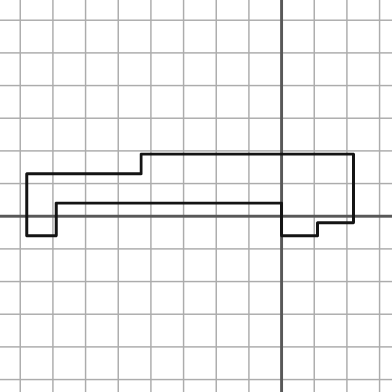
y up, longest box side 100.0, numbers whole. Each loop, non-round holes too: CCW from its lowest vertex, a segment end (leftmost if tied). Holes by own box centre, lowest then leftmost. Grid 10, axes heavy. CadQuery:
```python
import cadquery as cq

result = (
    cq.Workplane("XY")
    .moveTo(-78.0, -6.0)
    .lineTo(-69.0, -6.0)
    .lineTo(-69.0, 4.0)
    .lineTo(0.0, 4.0)
    .lineTo(0.0, -6.0)
    .lineTo(11.0, -6.0)
    .lineTo(11.0, -2.0)
    .lineTo(22.0, -2.0)
    .lineTo(22.0, 19.0)
    .lineTo(-43.0, 19.0)
    .lineTo(-43.0, 13.0)
    .lineTo(-78.0, 13.0)
    .close()
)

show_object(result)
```